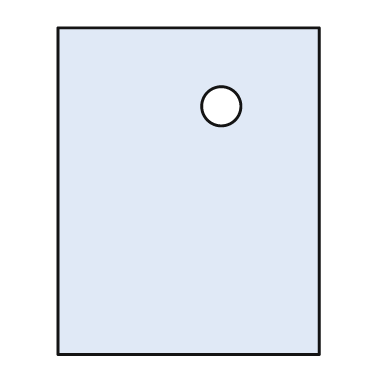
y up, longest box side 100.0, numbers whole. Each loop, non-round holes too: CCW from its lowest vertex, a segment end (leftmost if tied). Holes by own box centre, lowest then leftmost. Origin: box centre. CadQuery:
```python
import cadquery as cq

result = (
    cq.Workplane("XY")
    .moveTo(-40.0, -50.0)
    .lineTo(40.0, -50.0)
    .lineTo(40.0, 50.0)
    .lineTo(-40.0, 50.0)
    .close()
    .moveTo(10.0, 26.0)
    .circle(6.0)
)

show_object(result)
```